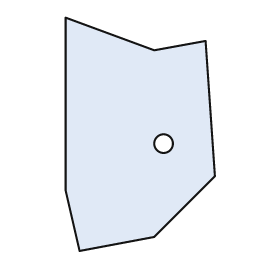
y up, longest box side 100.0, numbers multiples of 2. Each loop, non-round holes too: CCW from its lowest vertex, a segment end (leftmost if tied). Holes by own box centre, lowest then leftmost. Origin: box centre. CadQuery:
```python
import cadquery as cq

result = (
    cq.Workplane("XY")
    .moveTo(-26.0, -50.0)
    .lineTo(6.0, -44.0)
    .lineTo(32.0, -18.0)
    .lineTo(28.0, 40.0)
    .lineTo(6.0, 36.0)
    .lineTo(-32.0, 50.0)
    .lineTo(-32.0, -24.0)
    .close()
    .moveTo(10.0, -4.0)
    .circle(4.0)
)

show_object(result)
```